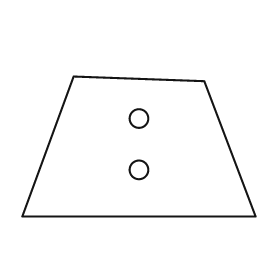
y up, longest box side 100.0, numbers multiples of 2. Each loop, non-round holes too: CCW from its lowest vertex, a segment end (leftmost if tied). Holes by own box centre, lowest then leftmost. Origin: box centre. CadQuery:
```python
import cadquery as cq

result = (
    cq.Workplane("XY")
    .moveTo(-50.0, -30.0)
    .lineTo(50.0, -30.0)
    .lineTo(28.0, 28.0)
    .lineTo(-28.0, 30.0)
    .close()
    .moveTo(0.0, -10.0)
    .circle(4.0)
    .moveTo(0.0, 12.0)
    .circle(4.0)
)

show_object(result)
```